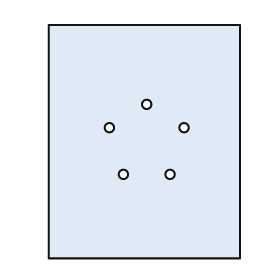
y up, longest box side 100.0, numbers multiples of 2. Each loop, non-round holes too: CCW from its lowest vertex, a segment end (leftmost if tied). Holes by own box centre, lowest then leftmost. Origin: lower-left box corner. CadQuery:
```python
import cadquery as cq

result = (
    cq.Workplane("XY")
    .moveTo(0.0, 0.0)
    .lineTo(82.0, 0.0)
    .lineTo(82.0, 100.0)
    .lineTo(0.0, 100.0)
    .close()
    .moveTo(32.0, 36.0)
    .circle(2.0)
    .moveTo(52.0, 36.0)
    .circle(2.0)
    .moveTo(26.0, 56.0)
    .circle(2.0)
    .moveTo(58.0, 56.0)
    .circle(2.0)
    .moveTo(42.0, 66.0)
    .circle(2.0)
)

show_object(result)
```